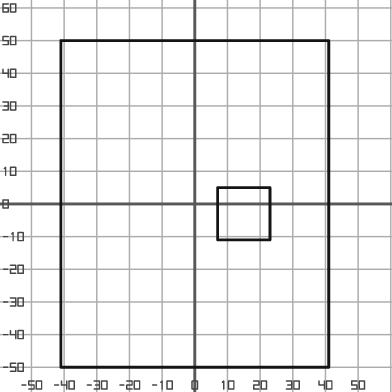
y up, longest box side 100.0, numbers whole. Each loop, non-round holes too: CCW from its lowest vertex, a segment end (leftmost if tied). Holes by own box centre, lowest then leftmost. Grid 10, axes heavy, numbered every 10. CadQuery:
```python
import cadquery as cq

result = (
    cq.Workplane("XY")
    .moveTo(-41.0, -50.0)
    .lineTo(41.0, -50.0)
    .lineTo(41.0, 50.0)
    .lineTo(-41.0, 50.0)
    .close()
    .moveTo(7.0, -11.0)
    .lineTo(23.0, -11.0)
    .lineTo(23.0, 5.0)
    .lineTo(7.0, 5.0)
    .close()
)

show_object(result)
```